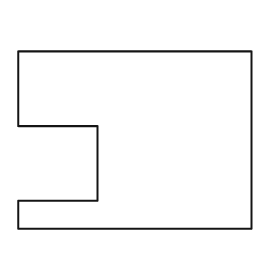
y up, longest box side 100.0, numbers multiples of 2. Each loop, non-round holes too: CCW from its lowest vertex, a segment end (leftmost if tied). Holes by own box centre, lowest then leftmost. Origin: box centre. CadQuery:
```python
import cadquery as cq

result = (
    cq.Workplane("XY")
    .moveTo(-50.0, -38.0)
    .lineTo(50.0, -38.0)
    .lineTo(50.0, 38.0)
    .lineTo(-50.0, 38.0)
    .lineTo(-50.0, 6.0)
    .lineTo(-16.0, 6.0)
    .lineTo(-16.0, -26.0)
    .lineTo(-50.0, -26.0)
    .close()
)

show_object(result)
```